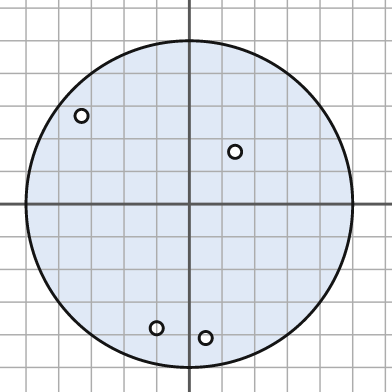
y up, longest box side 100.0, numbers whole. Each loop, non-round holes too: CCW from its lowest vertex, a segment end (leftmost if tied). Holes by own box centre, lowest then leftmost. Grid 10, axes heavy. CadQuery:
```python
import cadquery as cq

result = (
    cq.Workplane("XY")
    .moveTo(0.0, 0.0)
    .circle(50.0)
    .moveTo(5.0, -41.0)
    .circle(2.0)
    .moveTo(-10.0, -38.0)
    .circle(2.0)
    .moveTo(14.0, 16.0)
    .circle(2.0)
    .moveTo(-33.0, 27.0)
    .circle(2.0)
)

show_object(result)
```